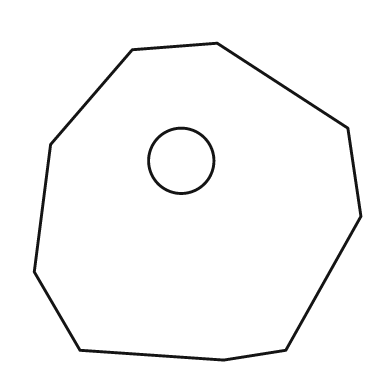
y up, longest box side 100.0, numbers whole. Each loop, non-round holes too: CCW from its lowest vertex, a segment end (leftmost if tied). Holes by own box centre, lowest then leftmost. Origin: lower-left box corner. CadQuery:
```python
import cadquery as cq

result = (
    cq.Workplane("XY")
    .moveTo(58.0, 0.0)
    .lineTo(77.0, 3.0)
    .lineTo(100.0, 44.0)
    .lineTo(96.0, 71.0)
    .lineTo(56.0, 97.0)
    .lineTo(30.0, 95.0)
    .lineTo(5.0, 66.0)
    .lineTo(0.0, 27.0)
    .lineTo(14.0, 3.0)
    .close()
    .moveTo(45.0, 61.0)
    .circle(10.0)
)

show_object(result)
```